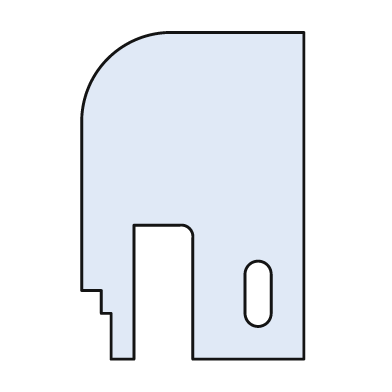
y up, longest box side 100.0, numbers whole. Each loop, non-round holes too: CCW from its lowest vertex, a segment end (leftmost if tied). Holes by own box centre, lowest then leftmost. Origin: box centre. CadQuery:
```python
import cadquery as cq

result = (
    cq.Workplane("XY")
    .moveTo(-25.0, -50.0)
    .lineTo(-18.0, -50.0)
    .lineTo(-18.0, -9.0)
    .lineTo(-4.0, -9.0)
    .threePointArc((-1.0, -10.0), (0.0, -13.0))
    .lineTo(0.0, -50.0)
    .lineTo(34.0, -50.0)
    .lineTo(34.0, 50.0)
    .lineTo(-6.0, 50.0)
    .threePointArc((-26.0, 42.0), (-34.0, 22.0))
    .lineTo(-34.0, -29.0)
    .lineTo(-28.0, -29.0)
    .lineTo(-28.0, -36.0)
    .lineTo(-25.0, -36.0)
    .close()
    .moveTo(16.0, -36.0)
    .threePointArc((20.0, -40.0), (24.0, -36.0))
    .lineTo(24.0, -24.0)
    .threePointArc((20.0, -20.0), (16.0, -24.0))
    .close()
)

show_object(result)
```